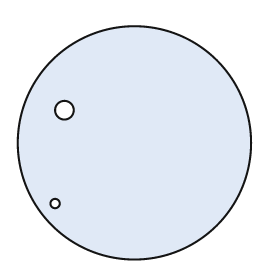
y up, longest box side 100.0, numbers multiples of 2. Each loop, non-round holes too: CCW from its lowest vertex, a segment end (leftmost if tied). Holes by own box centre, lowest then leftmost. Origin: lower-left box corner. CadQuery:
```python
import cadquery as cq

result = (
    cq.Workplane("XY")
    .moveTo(50.0, 50.0)
    .circle(50.0)
    .moveTo(16.0, 24.0)
    .circle(2.0)
    .moveTo(20.0, 64.0)
    .circle(4.0)
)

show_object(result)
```